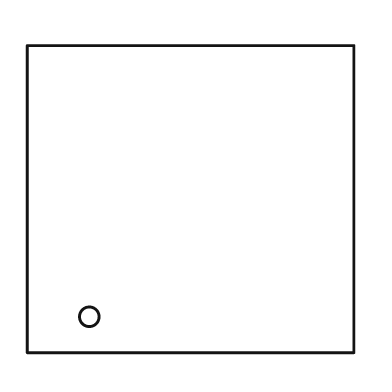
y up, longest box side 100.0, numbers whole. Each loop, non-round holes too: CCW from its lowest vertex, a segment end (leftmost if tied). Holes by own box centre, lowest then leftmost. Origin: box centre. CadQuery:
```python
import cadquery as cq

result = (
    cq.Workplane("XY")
    .moveTo(-50.0, -47.0)
    .lineTo(50.0, -47.0)
    .lineTo(50.0, 47.0)
    .lineTo(-50.0, 47.0)
    .close()
    .moveTo(-31.0, -36.0)
    .circle(3.0)
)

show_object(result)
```